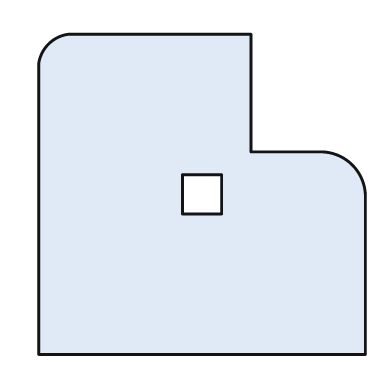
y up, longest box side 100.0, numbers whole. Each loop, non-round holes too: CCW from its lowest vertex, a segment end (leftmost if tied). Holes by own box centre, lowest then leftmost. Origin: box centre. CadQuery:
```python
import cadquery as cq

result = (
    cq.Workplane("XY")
    .moveTo(-50.0, -49.0)
    .lineTo(50.0, -49.0)
    .lineTo(50.0, 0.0)
    .threePointArc((46.0, 9.0), (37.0, 13.0))
    .lineTo(15.0, 13.0)
    .lineTo(15.0, 49.0)
    .lineTo(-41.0, 49.0)
    .threePointArc((-47.0, 46.0), (-50.0, 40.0))
    .close()
    .moveTo(-6.0, -6.0)
    .lineTo(6.0, -6.0)
    .lineTo(6.0, 6.0)
    .lineTo(-6.0, 6.0)
    .close()
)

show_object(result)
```